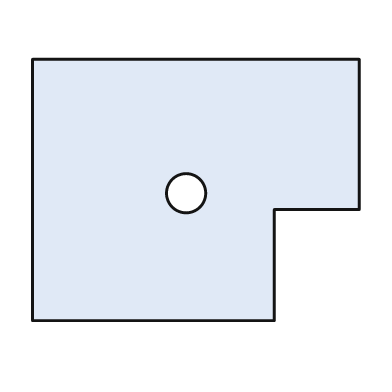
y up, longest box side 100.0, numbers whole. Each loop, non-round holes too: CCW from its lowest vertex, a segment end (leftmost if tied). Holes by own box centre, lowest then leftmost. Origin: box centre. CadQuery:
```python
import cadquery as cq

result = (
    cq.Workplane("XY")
    .moveTo(-50.0, -40.0)
    .lineTo(24.0, -40.0)
    .lineTo(24.0, -6.0)
    .lineTo(50.0, -6.0)
    .lineTo(50.0, 40.0)
    .lineTo(-50.0, 40.0)
    .close()
    .moveTo(-3.0, -1.0)
    .circle(6.0)
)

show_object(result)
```